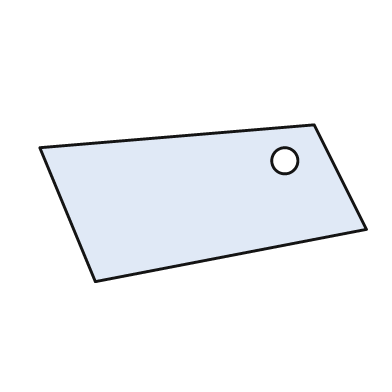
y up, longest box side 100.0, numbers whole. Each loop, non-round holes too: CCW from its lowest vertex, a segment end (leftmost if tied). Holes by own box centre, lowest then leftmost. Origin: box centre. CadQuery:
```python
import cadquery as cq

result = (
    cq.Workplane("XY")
    .moveTo(-33.0, -24.0)
    .lineTo(50.0, -8.0)
    .lineTo(34.0, 24.0)
    .lineTo(-50.0, 17.0)
    .close()
    .moveTo(25.0, 13.0)
    .circle(4.0)
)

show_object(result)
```